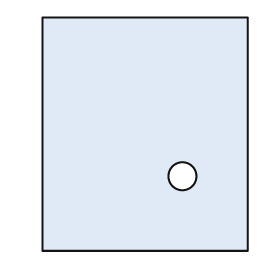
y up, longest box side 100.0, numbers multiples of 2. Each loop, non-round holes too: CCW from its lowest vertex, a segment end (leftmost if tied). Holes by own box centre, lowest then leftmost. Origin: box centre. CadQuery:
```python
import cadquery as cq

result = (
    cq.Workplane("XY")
    .moveTo(-44.0, -50.0)
    .lineTo(44.0, -50.0)
    .lineTo(44.0, 50.0)
    .lineTo(-44.0, 50.0)
    .close()
    .moveTo(16.0, -18.0)
    .circle(6.0)
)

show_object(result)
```